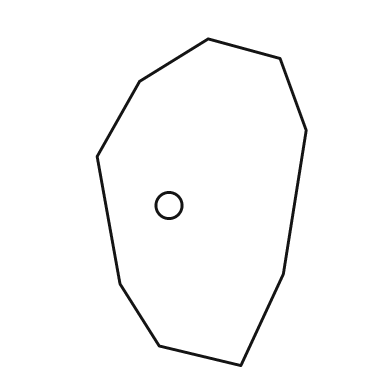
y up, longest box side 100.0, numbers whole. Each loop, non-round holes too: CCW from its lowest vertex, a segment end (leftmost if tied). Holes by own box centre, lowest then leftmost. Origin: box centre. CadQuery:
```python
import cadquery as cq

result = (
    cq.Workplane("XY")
    .moveTo(12.0, -50.0)
    .lineTo(25.0, -22.0)
    .lineTo(32.0, 22.0)
    .lineTo(24.0, 44.0)
    .lineTo(2.0, 50.0)
    .lineTo(-19.0, 37.0)
    .lineTo(-32.0, 14.0)
    .lineTo(-25.0, -25.0)
    .lineTo(-13.0, -44.0)
    .close()
    .moveTo(-10.0, -1.0)
    .circle(4.0)
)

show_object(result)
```